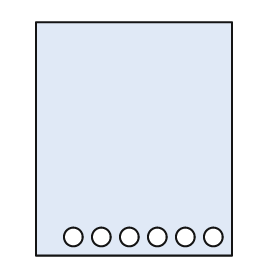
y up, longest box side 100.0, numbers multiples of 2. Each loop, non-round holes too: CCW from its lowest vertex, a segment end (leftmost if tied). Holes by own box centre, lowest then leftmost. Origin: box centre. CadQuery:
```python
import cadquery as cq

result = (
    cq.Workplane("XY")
    .moveTo(-42.0, -50.0)
    .lineTo(42.0, -50.0)
    .lineTo(42.0, 50.0)
    .lineTo(-42.0, 50.0)
    .close()
    .moveTo(-26.0, -42.0)
    .circle(4.0)
    .moveTo(-14.0, -42.0)
    .circle(4.0)
    .moveTo(-2.0, -42.0)
    .circle(4.0)
    .moveTo(10.0, -42.0)
    .circle(4.0)
    .moveTo(22.0, -42.0)
    .circle(4.0)
    .moveTo(34.0, -42.0)
    .circle(4.0)
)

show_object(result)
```